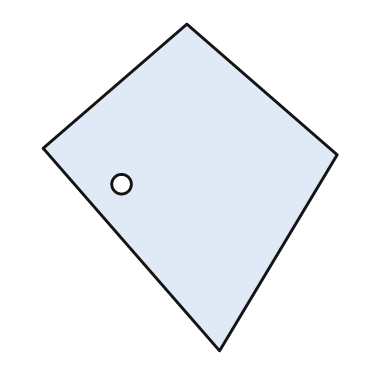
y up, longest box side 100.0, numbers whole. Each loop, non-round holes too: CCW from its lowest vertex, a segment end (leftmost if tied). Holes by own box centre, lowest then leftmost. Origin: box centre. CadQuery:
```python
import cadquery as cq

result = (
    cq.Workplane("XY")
    .moveTo(9.0, -50.0)
    .lineTo(45.0, 10.0)
    .lineTo(-1.0, 50.0)
    .lineTo(-45.0, 12.0)
    .close()
    .moveTo(-21.0, 1.0)
    .circle(3.0)
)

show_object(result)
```